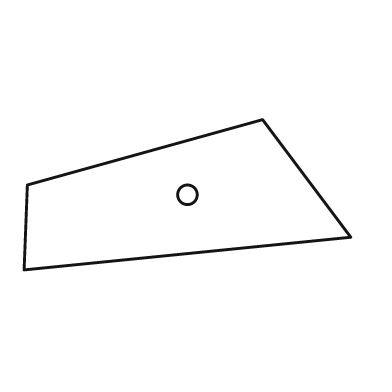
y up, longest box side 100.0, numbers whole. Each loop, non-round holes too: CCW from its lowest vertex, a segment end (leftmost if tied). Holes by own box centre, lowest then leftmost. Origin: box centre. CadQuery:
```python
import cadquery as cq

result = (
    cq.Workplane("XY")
    .moveTo(-50.0, -23.0)
    .lineTo(50.0, -13.0)
    .lineTo(23.0, 23.0)
    .lineTo(-49.0, 3.0)
    .close()
    .moveTo(0.0, 0.0)
    .circle(3.0)
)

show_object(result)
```